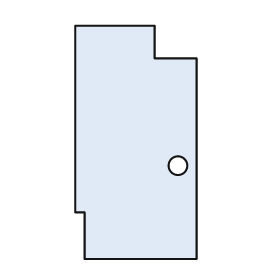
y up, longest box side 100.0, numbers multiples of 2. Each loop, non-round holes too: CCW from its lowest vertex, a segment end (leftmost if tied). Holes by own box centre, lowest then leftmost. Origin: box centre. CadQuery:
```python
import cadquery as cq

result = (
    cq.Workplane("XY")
    .moveTo(-22.0, -50.0)
    .lineTo(26.0, -50.0)
    .lineTo(26.0, 36.0)
    .lineTo(8.0, 36.0)
    .lineTo(8.0, 50.0)
    .lineTo(-26.0, 50.0)
    .lineTo(-26.0, -30.0)
    .lineTo(-22.0, -30.0)
    .close()
    .moveTo(18.0, -10.0)
    .circle(4.0)
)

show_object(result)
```